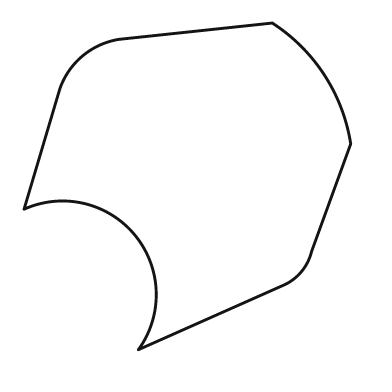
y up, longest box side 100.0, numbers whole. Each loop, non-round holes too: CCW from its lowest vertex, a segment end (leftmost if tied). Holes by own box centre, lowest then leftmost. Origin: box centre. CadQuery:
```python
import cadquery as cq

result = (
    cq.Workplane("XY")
    .moveTo(-15.0, -50.0)
    .lineTo(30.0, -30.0)
    .threePointArc((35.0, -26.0), (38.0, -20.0))
    .lineTo(50.0, 13.0)
    .threePointArc((42.0, 34.0), (26.0, 50.0))
    .lineTo(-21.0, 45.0)
    .threePointArc((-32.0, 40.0), (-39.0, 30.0))
    .lineTo(-50.0, -7.0)
    .threePointArc((-16.0, -15.0), (-15.0, -50.0))
    .close()
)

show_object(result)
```